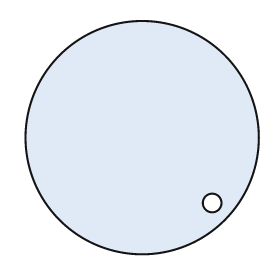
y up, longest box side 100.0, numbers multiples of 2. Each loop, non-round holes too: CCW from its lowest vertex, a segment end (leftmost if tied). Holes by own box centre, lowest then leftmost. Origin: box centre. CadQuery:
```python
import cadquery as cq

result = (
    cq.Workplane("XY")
    .moveTo(0.0, 0.0)
    .circle(50.0)
    .moveTo(30.0, -28.0)
    .circle(4.0)
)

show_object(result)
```